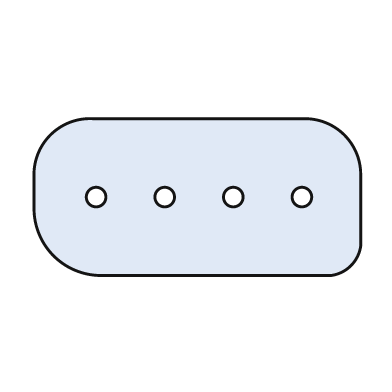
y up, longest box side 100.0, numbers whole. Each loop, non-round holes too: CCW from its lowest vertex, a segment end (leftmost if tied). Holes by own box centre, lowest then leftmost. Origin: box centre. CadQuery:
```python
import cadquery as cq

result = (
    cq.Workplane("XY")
    .moveTo(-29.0, -24.0)
    .lineTo(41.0, -24.0)
    .threePointArc((47.0, -21.0), (50.0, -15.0))
    .lineTo(50.0, 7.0)
    .threePointArc((45.0, 19.0), (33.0, 24.0))
    .lineTo(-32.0, 24.0)
    .threePointArc((-45.0, 19.0), (-50.0, 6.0))
    .lineTo(-50.0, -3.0)
    .threePointArc((-44.0, -18.0), (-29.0, -24.0))
    .close()
    .moveTo(-31.0, 0.0)
    .circle(3.0)
    .moveTo(-10.0, 0.0)
    .circle(3.0)
    .moveTo(11.0, 0.0)
    .circle(3.0)
    .moveTo(32.0, 0.0)
    .circle(3.0)
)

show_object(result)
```